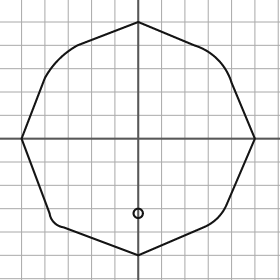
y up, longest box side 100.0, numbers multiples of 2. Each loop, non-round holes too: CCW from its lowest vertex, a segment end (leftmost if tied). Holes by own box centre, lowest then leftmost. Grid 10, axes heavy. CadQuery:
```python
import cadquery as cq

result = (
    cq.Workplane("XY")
    .moveTo(0.0, -50.0)
    .lineTo(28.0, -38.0)
    .threePointArc((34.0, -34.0), (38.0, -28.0))
    .lineTo(50.0, 0.0)
    .lineTo(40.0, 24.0)
    .threePointArc((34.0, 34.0), (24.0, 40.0))
    .lineTo(0.0, 50.0)
    .lineTo(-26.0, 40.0)
    .threePointArc((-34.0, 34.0), (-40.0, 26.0))
    .lineTo(-50.0, 0.0)
    .lineTo(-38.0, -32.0)
    .threePointArc((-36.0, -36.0), (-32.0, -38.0))
    .close()
    .moveTo(0.0, -32.0)
    .circle(2.0)
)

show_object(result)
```